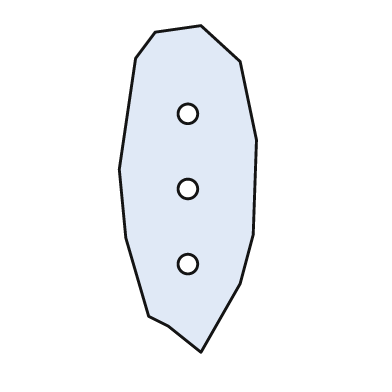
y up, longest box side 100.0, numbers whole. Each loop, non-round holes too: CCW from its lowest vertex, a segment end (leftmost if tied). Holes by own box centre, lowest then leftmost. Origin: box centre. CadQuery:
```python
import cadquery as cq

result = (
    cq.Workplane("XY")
    .moveTo(4.0, -50.0)
    .lineTo(16.0, -29.0)
    .lineTo(20.0, -14.0)
    .lineTo(21.0, 15.0)
    .lineTo(16.0, 39.0)
    .lineTo(4.0, 50.0)
    .lineTo(-10.0, 48.0)
    .lineTo(-16.0, 40.0)
    .lineTo(-21.0, 6.0)
    .lineTo(-19.0, -15.0)
    .lineTo(-12.0, -39.0)
    .lineTo(-6.0, -42.0)
    .close()
    .moveTo(0.0, -23.0)
    .circle(3.0)
    .moveTo(0.0, 0.0)
    .circle(3.0)
    .moveTo(0.0, 23.0)
    .circle(3.0)
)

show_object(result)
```